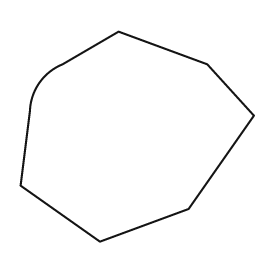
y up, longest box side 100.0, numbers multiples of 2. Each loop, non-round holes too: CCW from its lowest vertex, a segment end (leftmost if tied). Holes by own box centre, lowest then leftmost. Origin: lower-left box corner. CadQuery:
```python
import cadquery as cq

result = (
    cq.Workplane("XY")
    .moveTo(34.0, 0.0)
    .lineTo(72.0, 14.0)
    .lineTo(100.0, 54.0)
    .lineTo(80.0, 76.0)
    .lineTo(42.0, 90.0)
    .lineTo(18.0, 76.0)
    .threePointArc((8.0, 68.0), (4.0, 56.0))
    .lineTo(0.0, 24.0)
    .close()
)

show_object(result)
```